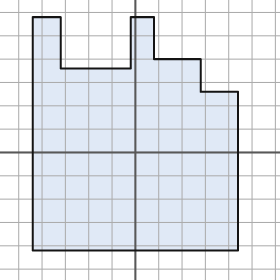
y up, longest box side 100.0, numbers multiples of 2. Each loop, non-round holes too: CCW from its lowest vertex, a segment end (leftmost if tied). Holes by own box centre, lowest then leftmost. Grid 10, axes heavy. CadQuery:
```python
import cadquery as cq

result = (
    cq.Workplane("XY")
    .moveTo(-44.0, -42.0)
    .lineTo(44.0, -42.0)
    .lineTo(44.0, 26.0)
    .lineTo(28.0, 26.0)
    .lineTo(28.0, 40.0)
    .lineTo(8.0, 40.0)
    .lineTo(8.0, 58.0)
    .lineTo(-2.0, 58.0)
    .lineTo(-2.0, 36.0)
    .lineTo(-32.0, 36.0)
    .lineTo(-32.0, 58.0)
    .lineTo(-44.0, 58.0)
    .close()
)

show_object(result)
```